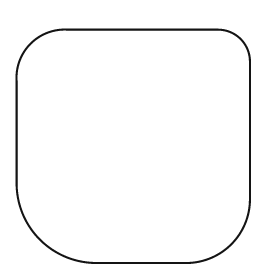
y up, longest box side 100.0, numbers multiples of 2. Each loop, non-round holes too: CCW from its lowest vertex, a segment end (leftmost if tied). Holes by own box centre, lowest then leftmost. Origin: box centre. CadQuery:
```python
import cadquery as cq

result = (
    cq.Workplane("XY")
    .moveTo(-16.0, -50.0)
    .lineTo(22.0, -50.0)
    .threePointArc((42.0, -42.0), (50.0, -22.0))
    .lineTo(50.0, 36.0)
    .threePointArc((46.0, 46.0), (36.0, 50.0))
    .lineTo(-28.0, 50.0)
    .threePointArc((-44.0, 44.0), (-50.0, 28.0))
    .lineTo(-50.0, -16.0)
    .threePointArc((-40.0, -40.0), (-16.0, -50.0))
    .close()
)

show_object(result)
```